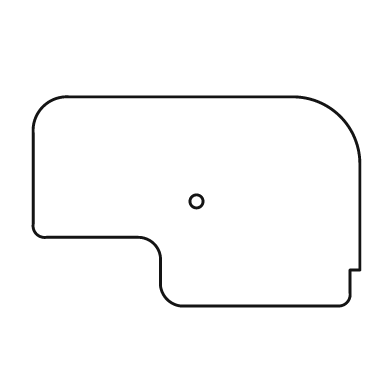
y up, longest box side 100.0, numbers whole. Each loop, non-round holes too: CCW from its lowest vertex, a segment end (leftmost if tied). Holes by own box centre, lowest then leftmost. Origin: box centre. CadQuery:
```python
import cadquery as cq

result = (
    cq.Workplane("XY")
    .moveTo(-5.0, -32.0)
    .lineTo(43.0, -32.0)
    .threePointArc((46.0, -31.0), (47.0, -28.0))
    .lineTo(47.0, -21.0)
    .lineTo(50.0, -21.0)
    .lineTo(50.0, 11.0)
    .threePointArc((44.0, 26.0), (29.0, 32.0))
    .lineTo(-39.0, 32.0)
    .threePointArc((-47.0, 29.0), (-50.0, 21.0))
    .lineTo(-50.0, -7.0)
    .threePointArc((-49.0, -10.0), (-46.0, -11.0))
    .lineTo(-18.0, -11.0)
    .threePointArc((-13.0, -13.0), (-11.0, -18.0))
    .lineTo(-11.0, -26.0)
    .threePointArc((-9.0, -30.0), (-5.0, -32.0))
    .close()
    .moveTo(0.0, 0.0)
    .circle(2.0)
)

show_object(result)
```